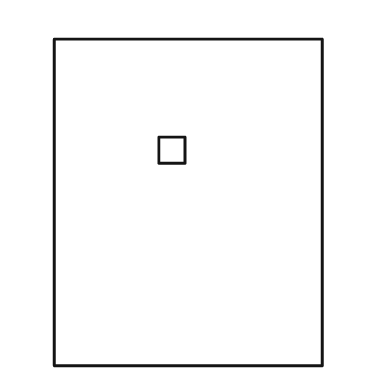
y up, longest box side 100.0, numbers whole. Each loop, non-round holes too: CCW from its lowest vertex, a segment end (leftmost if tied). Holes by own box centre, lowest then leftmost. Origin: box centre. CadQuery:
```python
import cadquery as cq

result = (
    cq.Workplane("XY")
    .moveTo(-41.0, -50.0)
    .lineTo(41.0, -50.0)
    .lineTo(41.0, 50.0)
    .lineTo(-41.0, 50.0)
    .close()
    .moveTo(-9.0, 12.0)
    .lineTo(-1.0, 12.0)
    .lineTo(-1.0, 20.0)
    .lineTo(-9.0, 20.0)
    .close()
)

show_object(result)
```